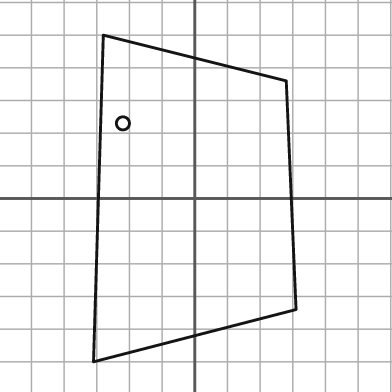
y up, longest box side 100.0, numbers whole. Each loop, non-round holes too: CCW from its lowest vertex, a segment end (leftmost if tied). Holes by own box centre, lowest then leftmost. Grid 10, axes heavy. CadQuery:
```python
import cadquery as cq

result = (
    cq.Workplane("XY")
    .moveTo(-31.0, -50.0)
    .lineTo(31.0, -34.0)
    .lineTo(28.0, 36.0)
    .lineTo(-28.0, 50.0)
    .close()
    .moveTo(-22.0, 23.0)
    .circle(2.0)
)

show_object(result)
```